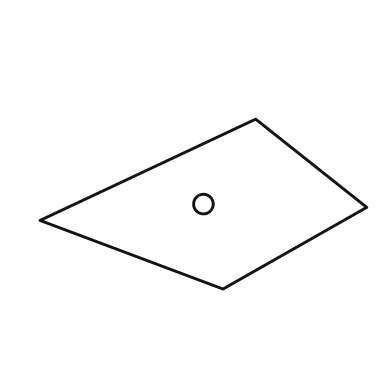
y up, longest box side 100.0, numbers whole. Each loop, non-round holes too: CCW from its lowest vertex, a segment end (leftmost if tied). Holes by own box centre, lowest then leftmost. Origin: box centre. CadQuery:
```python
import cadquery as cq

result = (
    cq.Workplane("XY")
    .moveTo(6.0, -26.0)
    .lineTo(50.0, -1.0)
    .lineTo(16.0, 26.0)
    .lineTo(-50.0, -5.0)
    .close()
    .moveTo(0.0, 0.0)
    .circle(3.0)
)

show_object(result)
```